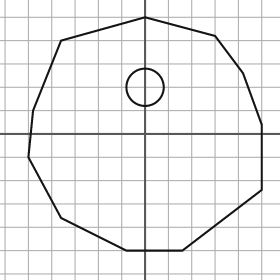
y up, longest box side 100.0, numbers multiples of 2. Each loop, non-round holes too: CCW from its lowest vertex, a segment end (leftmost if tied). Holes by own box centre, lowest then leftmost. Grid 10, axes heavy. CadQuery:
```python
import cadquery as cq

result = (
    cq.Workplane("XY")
    .moveTo(-8.0, -50.0)
    .lineTo(16.0, -50.0)
    .lineTo(50.0, -24.0)
    .lineTo(50.0, 4.0)
    .lineTo(42.0, 26.0)
    .lineTo(30.0, 42.0)
    .lineTo(0.0, 50.0)
    .lineTo(-36.0, 40.0)
    .lineTo(-48.0, 10.0)
    .lineTo(-50.0, -10.0)
    .lineTo(-36.0, -36.0)
    .close()
    .moveTo(0.0, 20.0)
    .circle(8.0)
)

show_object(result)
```